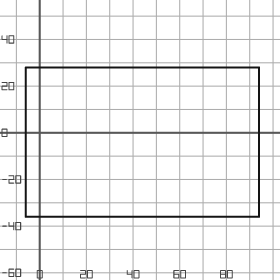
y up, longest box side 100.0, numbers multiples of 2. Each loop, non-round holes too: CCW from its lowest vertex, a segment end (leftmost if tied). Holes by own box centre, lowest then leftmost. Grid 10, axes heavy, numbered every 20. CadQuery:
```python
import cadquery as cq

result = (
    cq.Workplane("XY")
    .moveTo(-6.0, -36.0)
    .lineTo(94.0, -36.0)
    .lineTo(94.0, 28.0)
    .lineTo(-6.0, 28.0)
    .close()
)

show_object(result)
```